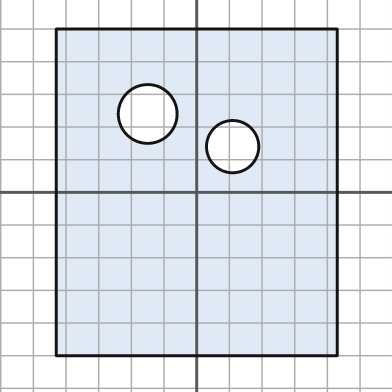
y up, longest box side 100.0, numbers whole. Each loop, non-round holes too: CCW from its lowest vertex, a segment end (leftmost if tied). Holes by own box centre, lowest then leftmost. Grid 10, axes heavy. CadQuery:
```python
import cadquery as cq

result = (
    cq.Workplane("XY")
    .moveTo(-43.0, -50.0)
    .lineTo(43.0, -50.0)
    .lineTo(43.0, 50.0)
    .lineTo(-43.0, 50.0)
    .close()
    .moveTo(11.0, 14.0)
    .circle(8.0)
    .moveTo(-15.0, 24.0)
    .circle(9.0)
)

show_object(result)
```